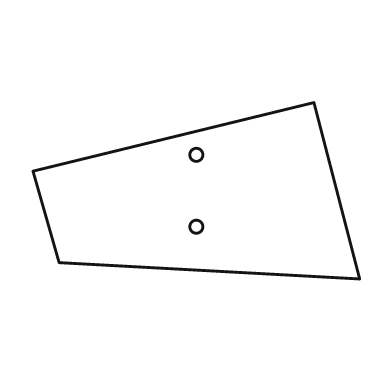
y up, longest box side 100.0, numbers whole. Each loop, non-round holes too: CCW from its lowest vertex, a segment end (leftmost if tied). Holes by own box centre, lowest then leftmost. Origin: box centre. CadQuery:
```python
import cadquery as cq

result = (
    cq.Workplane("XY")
    .moveTo(50.0, -27.0)
    .lineTo(36.0, 27.0)
    .lineTo(-50.0, 6.0)
    .lineTo(-42.0, -22.0)
    .close()
    .moveTo(0.0, -11.0)
    .circle(2.0)
    .moveTo(0.0, 11.0)
    .circle(2.0)
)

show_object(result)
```